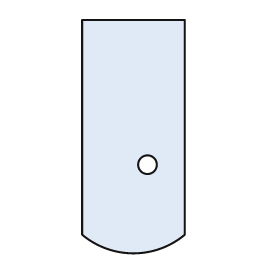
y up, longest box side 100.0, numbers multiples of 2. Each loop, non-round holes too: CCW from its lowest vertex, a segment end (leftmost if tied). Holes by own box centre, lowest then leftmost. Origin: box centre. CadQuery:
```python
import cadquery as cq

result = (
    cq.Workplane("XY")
    .moveTo(-22.0, -42.0)
    .threePointArc((0.0, -50.0), (22.0, -42.0))
    .lineTo(22.0, 50.0)
    .lineTo(-22.0, 50.0)
    .close()
    .moveTo(6.0, -12.0)
    .circle(4.0)
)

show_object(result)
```